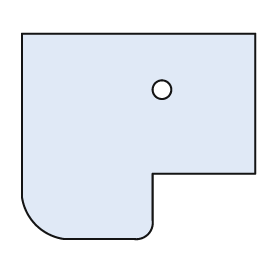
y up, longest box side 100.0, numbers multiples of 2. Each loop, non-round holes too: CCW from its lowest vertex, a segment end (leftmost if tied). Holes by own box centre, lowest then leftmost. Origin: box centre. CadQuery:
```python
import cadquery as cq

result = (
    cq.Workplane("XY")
    .moveTo(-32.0, -44.0)
    .lineTo(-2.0, -44.0)
    .threePointArc((4.0, -42.0), (6.0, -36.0))
    .lineTo(6.0, -16.0)
    .lineTo(50.0, -16.0)
    .lineTo(50.0, 44.0)
    .lineTo(-50.0, 44.0)
    .lineTo(-50.0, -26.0)
    .threePointArc((-44.0, -38.0), (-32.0, -44.0))
    .close()
    .moveTo(10.0, 20.0)
    .circle(4.0)
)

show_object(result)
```